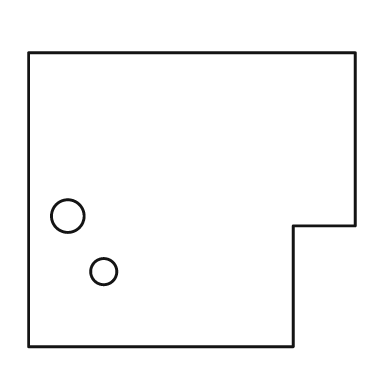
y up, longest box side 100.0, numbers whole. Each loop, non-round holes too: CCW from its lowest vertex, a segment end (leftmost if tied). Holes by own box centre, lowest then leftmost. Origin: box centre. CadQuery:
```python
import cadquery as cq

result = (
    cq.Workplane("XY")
    .moveTo(-50.0, -45.0)
    .lineTo(31.0, -45.0)
    .lineTo(31.0, -8.0)
    .lineTo(50.0, -8.0)
    .lineTo(50.0, 45.0)
    .lineTo(-50.0, 45.0)
    .close()
    .moveTo(-27.0, -22.0)
    .circle(4.0)
    .moveTo(-38.0, -5.0)
    .circle(5.0)
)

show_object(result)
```